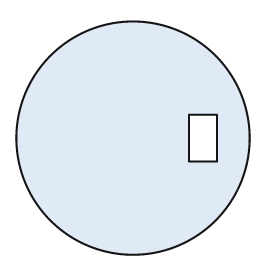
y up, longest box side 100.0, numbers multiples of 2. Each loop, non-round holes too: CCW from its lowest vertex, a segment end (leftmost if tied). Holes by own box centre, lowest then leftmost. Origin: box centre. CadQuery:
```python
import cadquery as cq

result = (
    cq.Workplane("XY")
    .moveTo(0.0, 0.0)
    .circle(50.0)
    .moveTo(24.0, -10.0)
    .lineTo(36.0, -10.0)
    .lineTo(36.0, 10.0)
    .lineTo(24.0, 10.0)
    .close()
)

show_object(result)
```